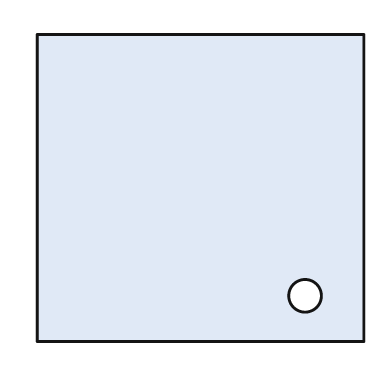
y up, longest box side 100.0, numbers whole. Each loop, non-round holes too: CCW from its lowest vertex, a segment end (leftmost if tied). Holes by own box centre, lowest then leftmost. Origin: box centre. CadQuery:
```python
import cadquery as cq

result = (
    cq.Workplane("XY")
    .moveTo(-50.0, -47.0)
    .lineTo(50.0, -47.0)
    .lineTo(50.0, 47.0)
    .lineTo(-50.0, 47.0)
    .close()
    .moveTo(32.0, -33.0)
    .circle(5.0)
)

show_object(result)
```